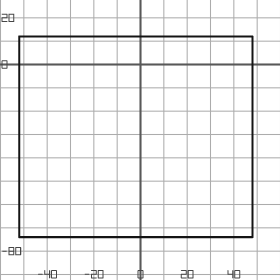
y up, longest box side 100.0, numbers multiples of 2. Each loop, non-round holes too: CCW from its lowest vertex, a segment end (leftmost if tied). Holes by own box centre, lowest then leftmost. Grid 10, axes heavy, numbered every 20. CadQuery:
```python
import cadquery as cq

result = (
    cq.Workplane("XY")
    .moveTo(-52.0, -74.0)
    .lineTo(48.0, -74.0)
    .lineTo(48.0, 12.0)
    .lineTo(-52.0, 12.0)
    .close()
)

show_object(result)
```